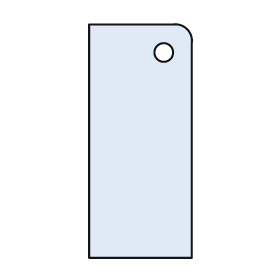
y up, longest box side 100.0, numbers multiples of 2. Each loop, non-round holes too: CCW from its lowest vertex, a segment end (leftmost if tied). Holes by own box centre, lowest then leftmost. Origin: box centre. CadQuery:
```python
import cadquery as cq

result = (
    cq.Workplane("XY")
    .moveTo(-22.0, -50.0)
    .lineTo(22.0, -50.0)
    .lineTo(22.0, 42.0)
    .threePointArc((20.0, 48.0), (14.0, 50.0))
    .lineTo(-22.0, 50.0)
    .close()
    .moveTo(10.0, 38.0)
    .circle(4.0)
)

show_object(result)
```